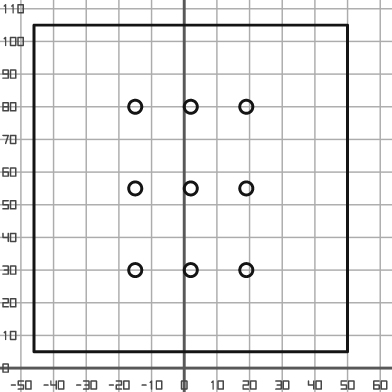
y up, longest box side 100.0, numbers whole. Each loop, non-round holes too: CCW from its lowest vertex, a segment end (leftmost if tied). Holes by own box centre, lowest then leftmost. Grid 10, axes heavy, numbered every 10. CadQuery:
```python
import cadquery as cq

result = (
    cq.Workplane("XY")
    .moveTo(-46.0, 5.0)
    .lineTo(50.0, 5.0)
    .lineTo(50.0, 105.0)
    .lineTo(-46.0, 105.0)
    .close()
    .moveTo(-15.0, 30.0)
    .circle(2.0)
    .moveTo(2.0, 30.0)
    .circle(2.0)
    .moveTo(19.0, 30.0)
    .circle(2.0)
    .moveTo(-15.0, 55.0)
    .circle(2.0)
    .moveTo(2.0, 55.0)
    .circle(2.0)
    .moveTo(19.0, 55.0)
    .circle(2.0)
    .moveTo(-15.0, 80.0)
    .circle(2.0)
    .moveTo(2.0, 80.0)
    .circle(2.0)
    .moveTo(19.0, 80.0)
    .circle(2.0)
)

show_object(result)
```